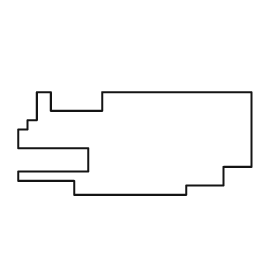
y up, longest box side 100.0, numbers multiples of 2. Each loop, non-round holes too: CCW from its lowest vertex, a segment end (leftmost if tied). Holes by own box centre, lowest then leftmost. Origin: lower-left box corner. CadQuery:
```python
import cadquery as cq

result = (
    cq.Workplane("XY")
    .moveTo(24.0, 0.0)
    .lineTo(72.0, 0.0)
    .lineTo(72.0, 4.0)
    .lineTo(88.0, 4.0)
    .lineTo(88.0, 12.0)
    .lineTo(100.0, 12.0)
    .lineTo(100.0, 44.0)
    .lineTo(36.0, 44.0)
    .lineTo(36.0, 36.0)
    .lineTo(14.0, 36.0)
    .lineTo(14.0, 44.0)
    .lineTo(8.0, 44.0)
    .lineTo(8.0, 32.0)
    .lineTo(4.0, 32.0)
    .lineTo(4.0, 28.0)
    .lineTo(0.0, 28.0)
    .lineTo(0.0, 20.0)
    .lineTo(30.0, 20.0)
    .lineTo(30.0, 10.0)
    .lineTo(0.0, 10.0)
    .lineTo(0.0, 6.0)
    .lineTo(24.0, 6.0)
    .close()
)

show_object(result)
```